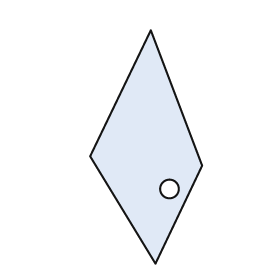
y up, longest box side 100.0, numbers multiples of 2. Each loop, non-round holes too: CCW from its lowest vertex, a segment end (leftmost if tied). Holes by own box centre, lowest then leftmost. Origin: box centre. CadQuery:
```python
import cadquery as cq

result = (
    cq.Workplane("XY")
    .moveTo(4.0, -50.0)
    .lineTo(24.0, -8.0)
    .lineTo(2.0, 50.0)
    .lineTo(-24.0, -4.0)
    .close()
    .moveTo(10.0, -18.0)
    .circle(4.0)
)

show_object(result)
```